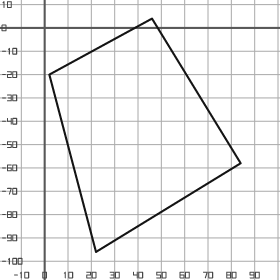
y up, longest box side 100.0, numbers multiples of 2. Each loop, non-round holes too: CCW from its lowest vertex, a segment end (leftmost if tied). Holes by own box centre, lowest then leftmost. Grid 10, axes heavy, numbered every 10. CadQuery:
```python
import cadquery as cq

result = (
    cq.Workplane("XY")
    .moveTo(22.0, -96.0)
    .lineTo(84.0, -58.0)
    .lineTo(46.0, 4.0)
    .lineTo(2.0, -20.0)
    .close()
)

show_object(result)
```